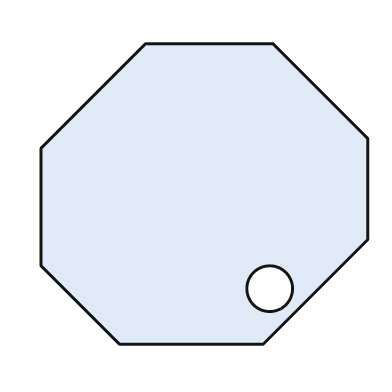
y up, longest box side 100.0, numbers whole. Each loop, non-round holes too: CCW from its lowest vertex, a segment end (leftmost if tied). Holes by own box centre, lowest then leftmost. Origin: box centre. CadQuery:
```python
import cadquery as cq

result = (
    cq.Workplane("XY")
    .moveTo(-26.0, -46.0)
    .lineTo(18.0, -46.0)
    .lineTo(50.0, -14.0)
    .lineTo(50.0, 17.0)
    .lineTo(21.0, 46.0)
    .lineTo(-18.0, 46.0)
    .lineTo(-50.0, 14.0)
    .lineTo(-50.0, -22.0)
    .close()
    .moveTo(20.0, -29.0)
    .circle(7.0)
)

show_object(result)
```